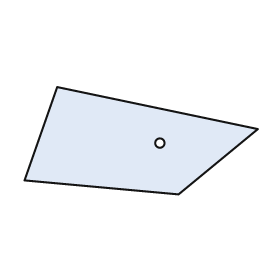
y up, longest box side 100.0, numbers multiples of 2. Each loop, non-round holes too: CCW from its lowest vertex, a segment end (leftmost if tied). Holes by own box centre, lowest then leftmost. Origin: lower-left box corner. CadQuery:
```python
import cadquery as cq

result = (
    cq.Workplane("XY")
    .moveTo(66.0, 0.0)
    .lineTo(100.0, 28.0)
    .lineTo(14.0, 46.0)
    .lineTo(0.0, 6.0)
    .close()
    .moveTo(58.0, 22.0)
    .circle(2.0)
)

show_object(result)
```